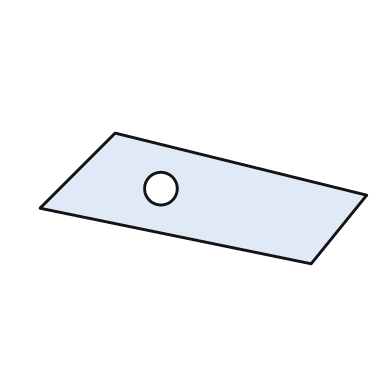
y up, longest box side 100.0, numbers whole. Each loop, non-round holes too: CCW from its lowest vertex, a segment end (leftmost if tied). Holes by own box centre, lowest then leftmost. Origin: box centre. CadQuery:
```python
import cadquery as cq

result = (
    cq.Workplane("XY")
    .moveTo(33.0, -20.0)
    .lineTo(50.0, 1.0)
    .lineTo(-27.0, 20.0)
    .lineTo(-50.0, -3.0)
    .close()
    .moveTo(-13.0, 3.0)
    .circle(5.0)
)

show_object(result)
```